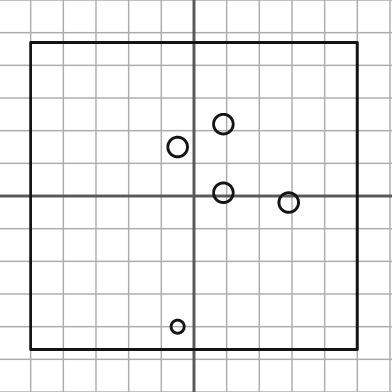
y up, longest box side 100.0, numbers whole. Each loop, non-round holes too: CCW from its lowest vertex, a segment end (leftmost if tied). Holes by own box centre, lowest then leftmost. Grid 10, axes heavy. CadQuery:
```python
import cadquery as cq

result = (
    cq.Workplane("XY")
    .moveTo(-50.0, -47.0)
    .lineTo(50.0, -47.0)
    .lineTo(50.0, 47.0)
    .lineTo(-50.0, 47.0)
    .close()
    .moveTo(-5.0, -40.0)
    .circle(2.0)
    .moveTo(29.0, -2.0)
    .circle(3.0)
    .moveTo(9.0, 1.0)
    .circle(3.0)
    .moveTo(-5.0, 15.0)
    .circle(3.0)
    .moveTo(9.0, 22.0)
    .circle(3.0)
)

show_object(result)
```